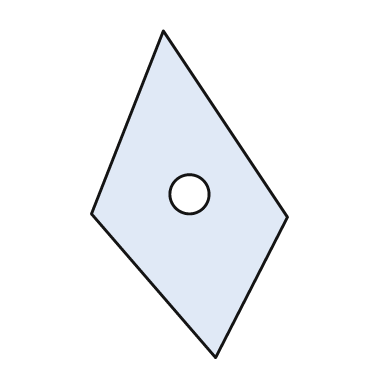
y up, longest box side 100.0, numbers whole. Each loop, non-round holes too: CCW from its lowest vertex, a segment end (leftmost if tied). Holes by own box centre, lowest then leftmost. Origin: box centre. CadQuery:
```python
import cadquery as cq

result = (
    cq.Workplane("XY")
    .moveTo(8.0, -50.0)
    .lineTo(30.0, -7.0)
    .lineTo(-8.0, 50.0)
    .lineTo(-30.0, -6.0)
    .close()
    .moveTo(0.0, 0.0)
    .circle(6.0)
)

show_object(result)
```